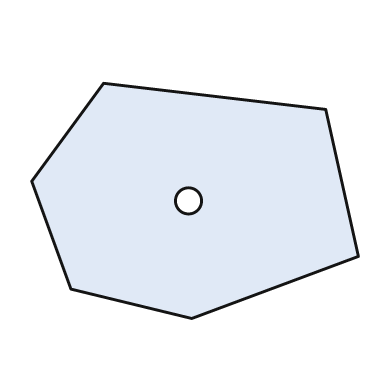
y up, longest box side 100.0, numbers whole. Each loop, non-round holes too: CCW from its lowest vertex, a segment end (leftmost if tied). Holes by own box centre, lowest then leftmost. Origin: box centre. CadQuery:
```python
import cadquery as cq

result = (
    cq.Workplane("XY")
    .moveTo(-1.0, -36.0)
    .lineTo(50.0, -17.0)
    .lineTo(40.0, 28.0)
    .lineTo(-28.0, 36.0)
    .lineTo(-50.0, 6.0)
    .lineTo(-38.0, -27.0)
    .close()
    .moveTo(-2.0, 0.0)
    .circle(4.0)
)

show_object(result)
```